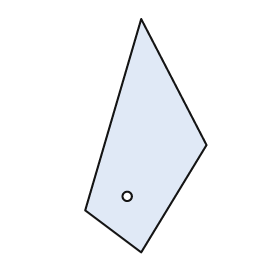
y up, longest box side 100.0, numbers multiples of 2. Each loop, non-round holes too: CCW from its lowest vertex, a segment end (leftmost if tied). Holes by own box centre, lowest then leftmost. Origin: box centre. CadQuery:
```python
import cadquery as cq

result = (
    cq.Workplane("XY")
    .moveTo(-2.0, -50.0)
    .lineTo(26.0, -4.0)
    .lineTo(-2.0, 50.0)
    .lineTo(-26.0, -32.0)
    .close()
    .moveTo(-8.0, -26.0)
    .circle(2.0)
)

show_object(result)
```